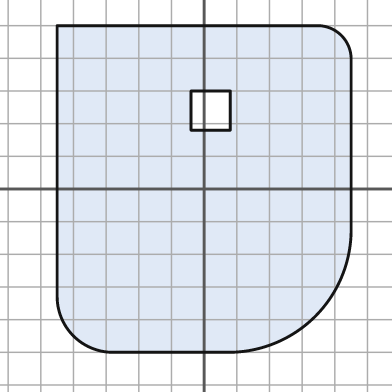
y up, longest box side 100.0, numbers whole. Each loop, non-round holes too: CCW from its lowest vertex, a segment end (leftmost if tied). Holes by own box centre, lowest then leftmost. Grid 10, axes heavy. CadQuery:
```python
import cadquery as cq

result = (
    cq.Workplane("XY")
    .moveTo(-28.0, -50.0)
    .lineTo(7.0, -50.0)
    .threePointArc((34.0, -39.0), (45.0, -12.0))
    .lineTo(45.0, 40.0)
    .threePointArc((42.0, 47.0), (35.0, 50.0))
    .lineTo(-45.0, 50.0)
    .lineTo(-45.0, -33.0)
    .threePointArc((-40.0, -45.0), (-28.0, -50.0))
    .close()
    .moveTo(-4.0, 18.0)
    .lineTo(8.0, 18.0)
    .lineTo(8.0, 30.0)
    .lineTo(-4.0, 30.0)
    .close()
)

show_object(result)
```